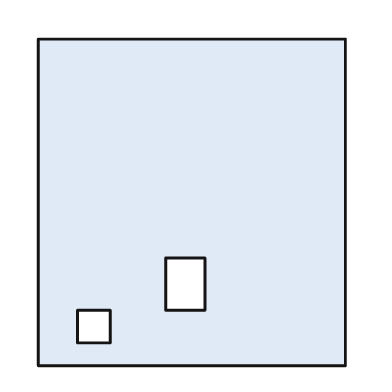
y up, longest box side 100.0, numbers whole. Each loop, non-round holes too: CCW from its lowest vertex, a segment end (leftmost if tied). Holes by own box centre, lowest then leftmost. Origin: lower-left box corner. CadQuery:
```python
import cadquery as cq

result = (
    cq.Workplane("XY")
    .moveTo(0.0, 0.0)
    .lineTo(94.0, 0.0)
    .lineTo(94.0, 100.0)
    .lineTo(0.0, 100.0)
    .close()
    .moveTo(12.0, 7.0)
    .lineTo(22.0, 7.0)
    .lineTo(22.0, 17.0)
    .lineTo(12.0, 17.0)
    .close()
    .moveTo(39.0, 17.0)
    .lineTo(51.0, 17.0)
    .lineTo(51.0, 33.0)
    .lineTo(39.0, 33.0)
    .close()
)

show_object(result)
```